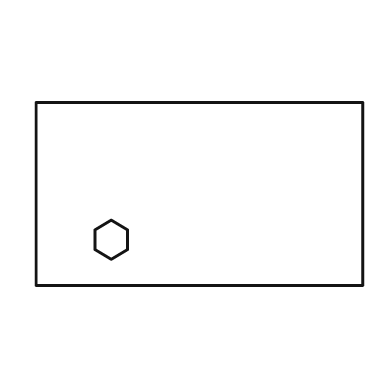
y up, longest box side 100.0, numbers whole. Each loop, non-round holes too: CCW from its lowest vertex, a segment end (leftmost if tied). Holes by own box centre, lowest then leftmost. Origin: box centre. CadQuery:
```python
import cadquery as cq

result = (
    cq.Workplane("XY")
    .moveTo(-50.0, -28.0)
    .lineTo(50.0, -28.0)
    .lineTo(50.0, 28.0)
    .lineTo(-50.0, 28.0)
    .close()
    .moveTo(-27.0, -20.0)
    .lineTo(-22.0, -17.0)
    .lineTo(-22.0, -11.0)
    .lineTo(-27.0, -8.0)
    .lineTo(-32.0, -11.0)
    .lineTo(-32.0, -17.0)
    .close()
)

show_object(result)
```